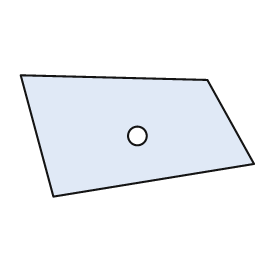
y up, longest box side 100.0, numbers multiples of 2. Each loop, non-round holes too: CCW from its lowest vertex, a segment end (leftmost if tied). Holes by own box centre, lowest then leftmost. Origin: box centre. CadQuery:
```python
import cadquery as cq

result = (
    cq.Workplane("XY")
    .moveTo(-36.0, -26.0)
    .lineTo(50.0, -12.0)
    .lineTo(30.0, 24.0)
    .lineTo(-50.0, 26.0)
    .close()
    .moveTo(0.0, 0.0)
    .circle(4.0)
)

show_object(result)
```